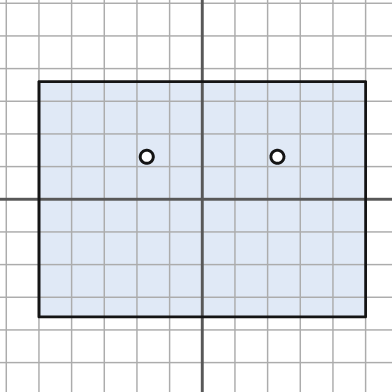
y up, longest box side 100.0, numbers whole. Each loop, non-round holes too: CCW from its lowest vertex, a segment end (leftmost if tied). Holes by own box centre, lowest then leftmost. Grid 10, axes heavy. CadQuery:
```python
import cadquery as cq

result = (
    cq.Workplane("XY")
    .moveTo(-50.0, -36.0)
    .lineTo(50.0, -36.0)
    .lineTo(50.0, 36.0)
    .lineTo(-50.0, 36.0)
    .close()
    .moveTo(-17.0, 13.0)
    .circle(2.0)
    .moveTo(23.0, 13.0)
    .circle(2.0)
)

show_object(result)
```